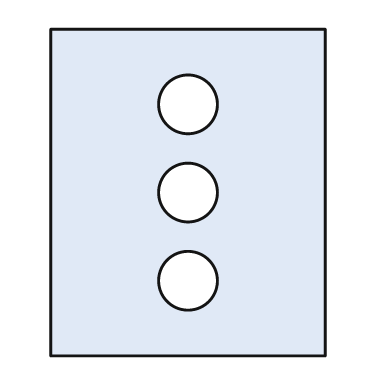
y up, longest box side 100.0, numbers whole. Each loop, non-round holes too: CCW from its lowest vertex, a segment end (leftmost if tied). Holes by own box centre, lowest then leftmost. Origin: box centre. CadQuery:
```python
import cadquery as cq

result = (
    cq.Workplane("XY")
    .moveTo(-42.0, -50.0)
    .lineTo(42.0, -50.0)
    .lineTo(42.0, 50.0)
    .lineTo(-42.0, 50.0)
    .close()
    .moveTo(0.0, -27.0)
    .circle(9.0)
    .moveTo(0.0, 0.0)
    .circle(9.0)
    .moveTo(0.0, 27.0)
    .circle(9.0)
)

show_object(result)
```